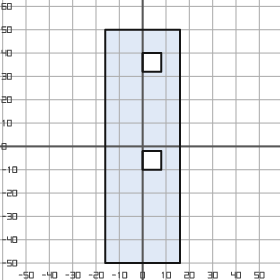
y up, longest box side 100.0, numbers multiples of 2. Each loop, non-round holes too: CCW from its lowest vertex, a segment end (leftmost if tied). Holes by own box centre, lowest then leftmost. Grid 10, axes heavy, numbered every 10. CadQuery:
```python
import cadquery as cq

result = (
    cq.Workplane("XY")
    .moveTo(-16.0, -50.0)
    .lineTo(16.0, -50.0)
    .lineTo(16.0, 50.0)
    .lineTo(-16.0, 50.0)
    .close()
    .moveTo(0.0, -10.0)
    .lineTo(8.0, -10.0)
    .lineTo(8.0, -2.0)
    .lineTo(0.0, -2.0)
    .close()
    .moveTo(0.0, 32.0)
    .lineTo(8.0, 32.0)
    .lineTo(8.0, 40.0)
    .lineTo(0.0, 40.0)
    .close()
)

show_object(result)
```